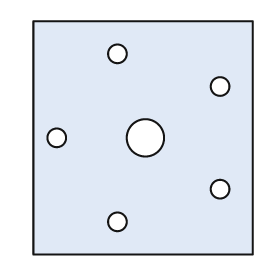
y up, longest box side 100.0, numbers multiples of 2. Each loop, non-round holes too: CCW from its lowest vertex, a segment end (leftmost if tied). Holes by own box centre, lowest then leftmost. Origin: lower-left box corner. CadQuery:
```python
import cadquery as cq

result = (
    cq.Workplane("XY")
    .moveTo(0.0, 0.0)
    .lineTo(94.0, 0.0)
    .lineTo(94.0, 100.0)
    .lineTo(0.0, 100.0)
    .close()
    .moveTo(36.0, 14.0)
    .circle(4.0)
    .moveTo(80.0, 28.0)
    .circle(4.0)
    .moveTo(10.0, 50.0)
    .circle(4.0)
    .moveTo(48.0, 50.0)
    .circle(8.0)
    .moveTo(80.0, 72.0)
    .circle(4.0)
    .moveTo(36.0, 86.0)
    .circle(4.0)
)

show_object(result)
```